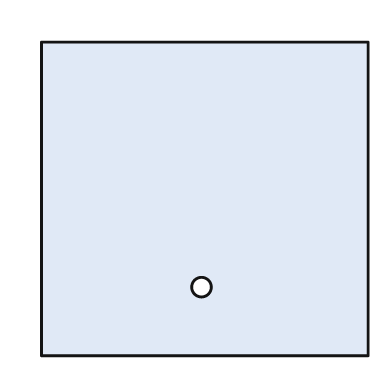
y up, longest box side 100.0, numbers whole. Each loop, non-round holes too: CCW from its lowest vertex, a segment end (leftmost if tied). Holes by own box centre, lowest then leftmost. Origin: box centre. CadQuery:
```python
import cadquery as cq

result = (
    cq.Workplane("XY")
    .moveTo(-50.0, -48.0)
    .lineTo(50.0, -48.0)
    .lineTo(50.0, 48.0)
    .lineTo(-50.0, 48.0)
    .close()
    .moveTo(-1.0, -27.0)
    .circle(3.0)
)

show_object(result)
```